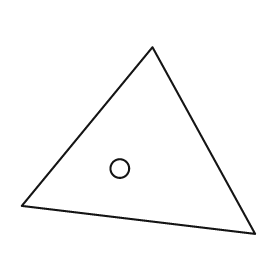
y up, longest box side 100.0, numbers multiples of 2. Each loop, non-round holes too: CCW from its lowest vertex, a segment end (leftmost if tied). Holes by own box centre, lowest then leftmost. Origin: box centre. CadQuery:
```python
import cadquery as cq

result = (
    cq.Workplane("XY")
    .moveTo(50.0, -40.0)
    .lineTo(6.0, 40.0)
    .lineTo(-50.0, -28.0)
    .close()
    .moveTo(-8.0, -12.0)
    .circle(4.0)
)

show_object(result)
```